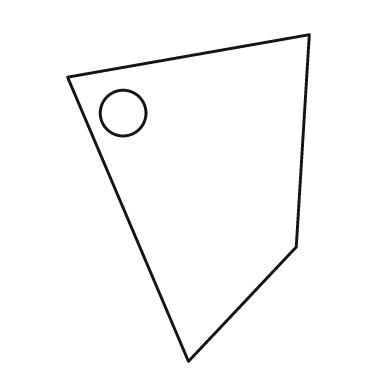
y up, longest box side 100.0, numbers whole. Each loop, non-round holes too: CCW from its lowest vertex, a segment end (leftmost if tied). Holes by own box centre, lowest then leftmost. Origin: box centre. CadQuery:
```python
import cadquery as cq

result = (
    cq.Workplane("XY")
    .moveTo(0.0, -50.0)
    .lineTo(33.0, -15.0)
    .lineTo(37.0, 50.0)
    .lineTo(-37.0, 37.0)
    .close()
    .moveTo(-20.0, 26.0)
    .circle(7.0)
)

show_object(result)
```